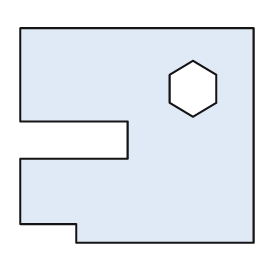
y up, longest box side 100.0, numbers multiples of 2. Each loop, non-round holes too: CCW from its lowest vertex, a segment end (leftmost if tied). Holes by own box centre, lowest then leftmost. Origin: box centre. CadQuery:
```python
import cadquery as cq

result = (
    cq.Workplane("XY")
    .moveTo(-26.0, -46.0)
    .lineTo(50.0, -46.0)
    .lineTo(50.0, 46.0)
    .lineTo(-50.0, 46.0)
    .lineTo(-50.0, 6.0)
    .lineTo(-4.0, 6.0)
    .lineTo(-4.0, -10.0)
    .lineTo(-50.0, -10.0)
    .lineTo(-50.0, -38.0)
    .lineTo(-26.0, -38.0)
    .close()
    .moveTo(24.0, 8.0)
    .lineTo(34.0, 14.0)
    .lineTo(34.0, 26.0)
    .lineTo(24.0, 32.0)
    .lineTo(14.0, 26.0)
    .lineTo(14.0, 14.0)
    .close()
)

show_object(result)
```